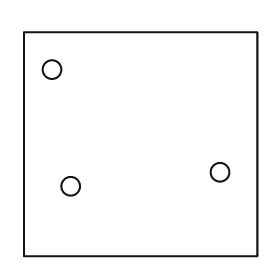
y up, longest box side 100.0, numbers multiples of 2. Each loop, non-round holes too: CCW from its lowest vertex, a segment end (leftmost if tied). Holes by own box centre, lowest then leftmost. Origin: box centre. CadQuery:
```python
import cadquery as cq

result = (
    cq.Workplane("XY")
    .moveTo(-50.0, -48.0)
    .lineTo(50.0, -48.0)
    .lineTo(50.0, 48.0)
    .lineTo(-50.0, 48.0)
    .close()
    .moveTo(-30.0, -18.0)
    .circle(4.0)
    .moveTo(34.0, -12.0)
    .circle(4.0)
    .moveTo(-38.0, 32.0)
    .circle(4.0)
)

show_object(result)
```